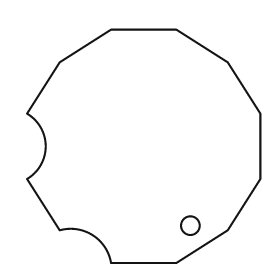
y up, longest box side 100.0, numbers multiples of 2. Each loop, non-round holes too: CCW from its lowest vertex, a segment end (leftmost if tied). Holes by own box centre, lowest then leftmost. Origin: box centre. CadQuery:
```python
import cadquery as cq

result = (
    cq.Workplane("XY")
    .moveTo(-14.0, -50.0)
    .lineTo(14.0, -50.0)
    .lineTo(36.0, -36.0)
    .lineTo(50.0, -14.0)
    .lineTo(50.0, 14.0)
    .lineTo(36.0, 36.0)
    .lineTo(14.0, 50.0)
    .lineTo(-14.0, 50.0)
    .lineTo(-36.0, 36.0)
    .lineTo(-50.0, 14.0)
    .threePointArc((-42.0, 0.0), (-50.0, -14.0))
    .lineTo(-36.0, -36.0)
    .threePointArc((-22.0, -38.0), (-14.0, -50.0))
    .close()
    .moveTo(20.0, -34.0)
    .circle(4.0)
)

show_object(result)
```